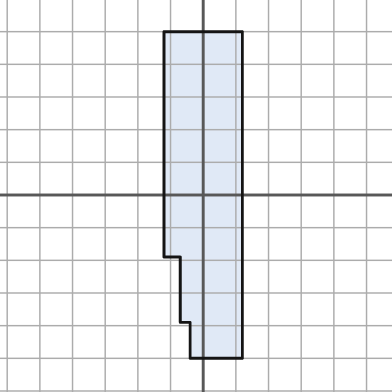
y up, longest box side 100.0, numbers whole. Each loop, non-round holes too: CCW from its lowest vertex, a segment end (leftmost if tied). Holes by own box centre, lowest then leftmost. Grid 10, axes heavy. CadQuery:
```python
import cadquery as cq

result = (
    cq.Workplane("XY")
    .moveTo(-4.0, -50.0)
    .lineTo(12.0, -50.0)
    .lineTo(12.0, 50.0)
    .lineTo(-12.0, 50.0)
    .lineTo(-12.0, -19.0)
    .lineTo(-7.0, -19.0)
    .lineTo(-7.0, -39.0)
    .lineTo(-4.0, -39.0)
    .close()
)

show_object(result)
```